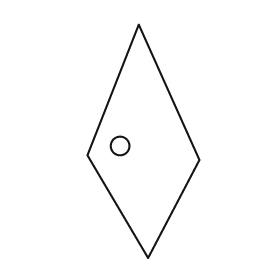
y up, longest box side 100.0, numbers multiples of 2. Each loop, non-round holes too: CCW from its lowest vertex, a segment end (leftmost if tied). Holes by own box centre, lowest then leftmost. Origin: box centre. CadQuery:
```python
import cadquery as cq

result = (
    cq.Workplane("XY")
    .moveTo(2.0, -50.0)
    .lineTo(24.0, -8.0)
    .lineTo(-2.0, 50.0)
    .lineTo(-24.0, -6.0)
    .close()
    .moveTo(-10.0, -2.0)
    .circle(4.0)
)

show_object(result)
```